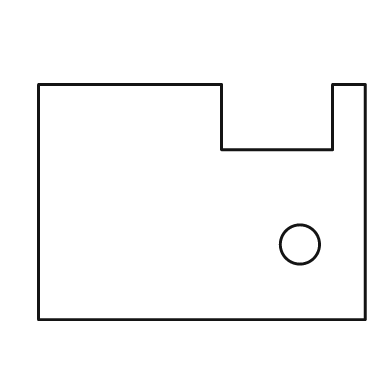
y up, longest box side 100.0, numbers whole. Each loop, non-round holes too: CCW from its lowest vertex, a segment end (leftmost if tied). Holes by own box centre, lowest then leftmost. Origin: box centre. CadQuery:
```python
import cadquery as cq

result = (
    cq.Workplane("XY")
    .moveTo(-50.0, -36.0)
    .lineTo(50.0, -36.0)
    .lineTo(50.0, 36.0)
    .lineTo(40.0, 36.0)
    .lineTo(40.0, 16.0)
    .lineTo(6.0, 16.0)
    .lineTo(6.0, 36.0)
    .lineTo(-50.0, 36.0)
    .close()
    .moveTo(30.0, -13.0)
    .circle(6.0)
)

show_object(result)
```